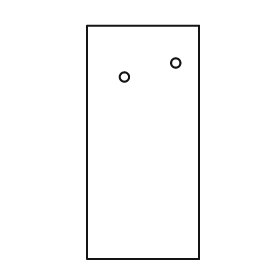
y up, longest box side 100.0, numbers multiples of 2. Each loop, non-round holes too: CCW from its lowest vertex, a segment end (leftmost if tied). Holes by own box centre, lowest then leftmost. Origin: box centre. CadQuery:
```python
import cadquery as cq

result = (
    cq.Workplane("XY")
    .moveTo(-24.0, -50.0)
    .lineTo(24.0, -50.0)
    .lineTo(24.0, 50.0)
    .lineTo(-24.0, 50.0)
    .close()
    .moveTo(-8.0, 28.0)
    .circle(2.0)
    .moveTo(14.0, 34.0)
    .circle(2.0)
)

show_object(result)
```